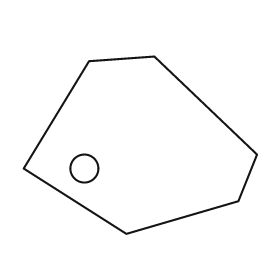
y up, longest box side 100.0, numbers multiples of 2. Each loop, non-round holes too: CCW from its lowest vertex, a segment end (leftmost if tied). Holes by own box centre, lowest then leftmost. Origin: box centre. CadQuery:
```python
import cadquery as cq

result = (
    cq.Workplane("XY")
    .moveTo(-6.0, -38.0)
    .lineTo(42.0, -24.0)
    .lineTo(50.0, -4.0)
    .lineTo(6.0, 38.0)
    .lineTo(-22.0, 36.0)
    .lineTo(-50.0, -10.0)
    .close()
    .moveTo(-24.0, -10.0)
    .circle(6.0)
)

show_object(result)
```